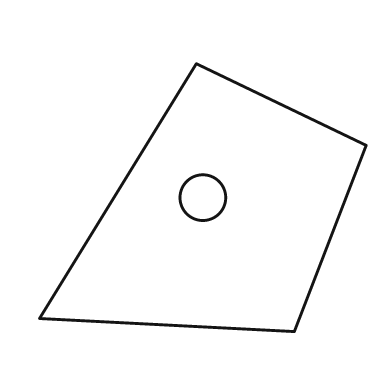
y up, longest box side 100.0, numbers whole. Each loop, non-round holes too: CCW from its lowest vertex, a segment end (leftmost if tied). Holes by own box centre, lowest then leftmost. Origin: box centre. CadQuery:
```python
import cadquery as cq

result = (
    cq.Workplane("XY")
    .moveTo(28.0, -41.0)
    .lineTo(50.0, 16.0)
    .lineTo(-2.0, 41.0)
    .lineTo(-50.0, -37.0)
    .close()
    .moveTo(0.0, 0.0)
    .circle(7.0)
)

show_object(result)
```